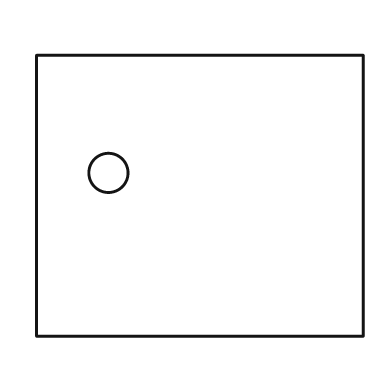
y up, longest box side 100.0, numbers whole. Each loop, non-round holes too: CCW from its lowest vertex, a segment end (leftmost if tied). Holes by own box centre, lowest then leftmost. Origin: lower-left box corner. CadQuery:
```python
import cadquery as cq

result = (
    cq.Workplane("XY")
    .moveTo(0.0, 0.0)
    .lineTo(100.0, 0.0)
    .lineTo(100.0, 86.0)
    .lineTo(0.0, 86.0)
    .close()
    .moveTo(22.0, 50.0)
    .circle(6.0)
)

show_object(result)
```